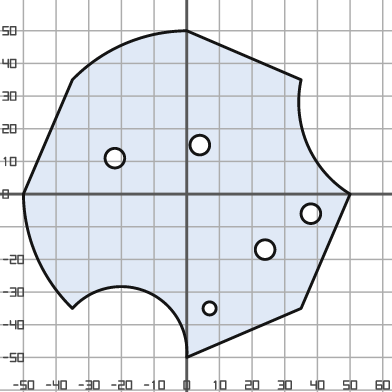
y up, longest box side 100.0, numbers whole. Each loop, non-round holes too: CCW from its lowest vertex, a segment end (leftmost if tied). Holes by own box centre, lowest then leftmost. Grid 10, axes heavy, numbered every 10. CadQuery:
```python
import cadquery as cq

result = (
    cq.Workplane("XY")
    .moveTo(0.0, -50.0)
    .lineTo(35.0, -35.0)
    .lineTo(50.0, 0.0)
    .threePointArc((37.0, 15.0), (35.0, 35.0))
    .lineTo(0.0, 50.0)
    .threePointArc((-19.0, 46.0), (-35.0, 35.0))
    .lineTo(-50.0, 0.0)
    .threePointArc((-46.0, -19.0), (-35.0, -35.0))
    .threePointArc((-12.0, -30.0), (0.0, -50.0))
    .close()
    .moveTo(7.0, -35.0)
    .circle(2.0)
    .moveTo(24.0, -17.0)
    .circle(3.0)
    .moveTo(38.0, -6.0)
    .circle(3.0)
    .moveTo(-22.0, 11.0)
    .circle(3.0)
    .moveTo(4.0, 15.0)
    .circle(3.0)
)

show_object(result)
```